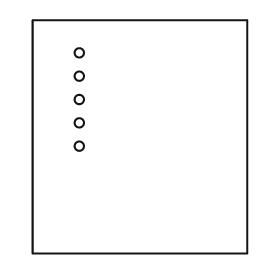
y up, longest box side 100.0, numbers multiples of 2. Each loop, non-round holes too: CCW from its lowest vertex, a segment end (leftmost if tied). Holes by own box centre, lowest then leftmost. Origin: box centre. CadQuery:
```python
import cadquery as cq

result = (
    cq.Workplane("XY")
    .moveTo(-46.0, -50.0)
    .lineTo(46.0, -50.0)
    .lineTo(46.0, 50.0)
    .lineTo(-46.0, 50.0)
    .close()
    .moveTo(-26.0, -4.0)
    .circle(2.0)
    .moveTo(-26.0, 6.0)
    .circle(2.0)
    .moveTo(-26.0, 16.0)
    .circle(2.0)
    .moveTo(-26.0, 26.0)
    .circle(2.0)
    .moveTo(-26.0, 36.0)
    .circle(2.0)
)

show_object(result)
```